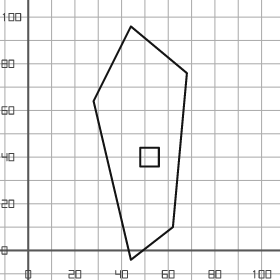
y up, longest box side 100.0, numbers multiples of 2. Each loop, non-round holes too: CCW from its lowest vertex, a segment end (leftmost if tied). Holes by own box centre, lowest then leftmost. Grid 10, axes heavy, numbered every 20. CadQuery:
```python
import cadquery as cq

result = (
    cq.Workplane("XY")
    .moveTo(44.0, -4.0)
    .lineTo(62.0, 10.0)
    .lineTo(68.0, 76.0)
    .lineTo(44.0, 96.0)
    .lineTo(28.0, 64.0)
    .close()
    .moveTo(48.0, 36.0)
    .lineTo(56.0, 36.0)
    .lineTo(56.0, 44.0)
    .lineTo(48.0, 44.0)
    .close()
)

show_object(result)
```